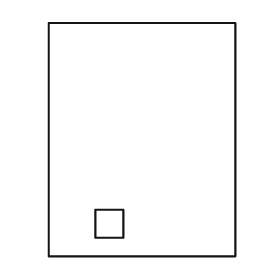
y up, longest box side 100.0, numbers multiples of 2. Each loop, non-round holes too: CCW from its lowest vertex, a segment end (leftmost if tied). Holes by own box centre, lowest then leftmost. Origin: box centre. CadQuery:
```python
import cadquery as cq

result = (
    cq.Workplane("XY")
    .moveTo(-40.0, -50.0)
    .lineTo(40.0, -50.0)
    .lineTo(40.0, 50.0)
    .lineTo(-40.0, 50.0)
    .close()
    .moveTo(-20.0, -42.0)
    .lineTo(-8.0, -42.0)
    .lineTo(-8.0, -30.0)
    .lineTo(-20.0, -30.0)
    .close()
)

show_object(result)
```